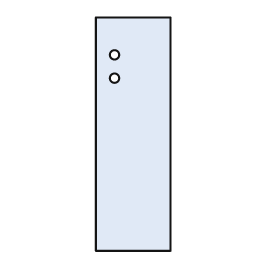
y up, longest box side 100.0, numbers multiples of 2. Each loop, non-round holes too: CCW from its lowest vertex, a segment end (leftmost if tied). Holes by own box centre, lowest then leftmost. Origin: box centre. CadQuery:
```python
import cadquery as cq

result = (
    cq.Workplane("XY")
    .moveTo(-16.0, -50.0)
    .lineTo(16.0, -50.0)
    .lineTo(16.0, 50.0)
    .lineTo(-16.0, 50.0)
    .close()
    .moveTo(-8.0, 24.0)
    .circle(2.0)
    .moveTo(-8.0, 34.0)
    .circle(2.0)
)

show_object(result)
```